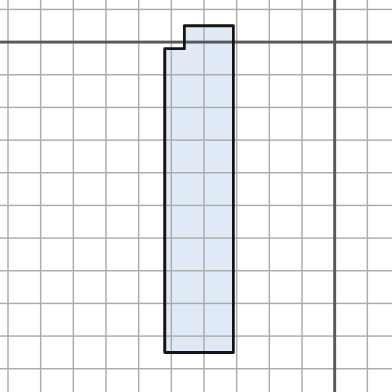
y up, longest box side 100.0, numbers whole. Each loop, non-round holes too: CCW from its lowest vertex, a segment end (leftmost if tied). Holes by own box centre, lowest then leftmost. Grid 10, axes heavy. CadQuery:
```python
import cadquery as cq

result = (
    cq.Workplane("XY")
    .moveTo(-52.0, -95.0)
    .lineTo(-31.0, -95.0)
    .lineTo(-31.0, 5.0)
    .lineTo(-46.0, 5.0)
    .lineTo(-46.0, -2.0)
    .lineTo(-52.0, -2.0)
    .close()
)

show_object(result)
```